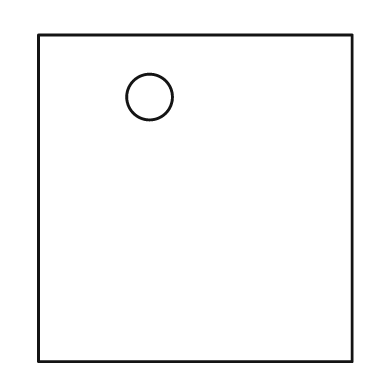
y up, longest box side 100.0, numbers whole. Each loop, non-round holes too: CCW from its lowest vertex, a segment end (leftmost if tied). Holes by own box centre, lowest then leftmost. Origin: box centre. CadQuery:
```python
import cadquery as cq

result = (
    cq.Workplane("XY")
    .moveTo(-48.0, -50.0)
    .lineTo(48.0, -50.0)
    .lineTo(48.0, 50.0)
    .lineTo(-48.0, 50.0)
    .close()
    .moveTo(-14.0, 31.0)
    .circle(7.0)
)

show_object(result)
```